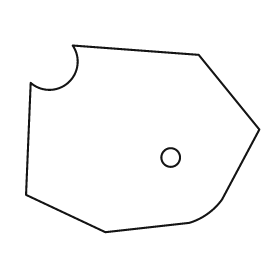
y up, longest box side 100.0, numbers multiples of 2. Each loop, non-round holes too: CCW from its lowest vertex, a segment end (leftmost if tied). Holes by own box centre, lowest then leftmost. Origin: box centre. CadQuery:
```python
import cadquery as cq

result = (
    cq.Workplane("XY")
    .moveTo(-16.0, -40.0)
    .lineTo(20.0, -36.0)
    .threePointArc((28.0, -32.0), (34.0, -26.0))
    .lineTo(50.0, 4.0)
    .lineTo(24.0, 36.0)
    .lineTo(-30.0, 40.0)
    .threePointArc((-32.0, 24.0), (-48.0, 24.0))
    .lineTo(-50.0, -24.0)
    .close()
    .moveTo(12.0, -8.0)
    .circle(4.0)
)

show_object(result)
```